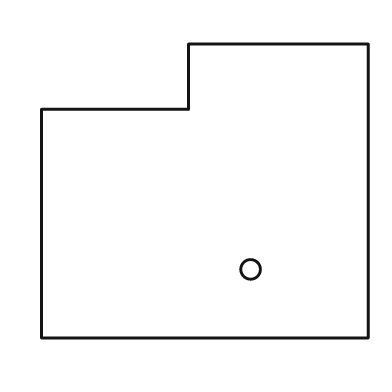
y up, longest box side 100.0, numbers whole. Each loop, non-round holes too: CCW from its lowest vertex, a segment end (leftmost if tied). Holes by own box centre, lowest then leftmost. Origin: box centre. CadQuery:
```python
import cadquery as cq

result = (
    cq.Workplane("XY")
    .moveTo(-50.0, -45.0)
    .lineTo(50.0, -45.0)
    .lineTo(50.0, 45.0)
    .lineTo(-5.0, 45.0)
    .lineTo(-5.0, 25.0)
    .lineTo(-50.0, 25.0)
    .close()
    .moveTo(14.0, -24.0)
    .circle(3.0)
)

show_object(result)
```